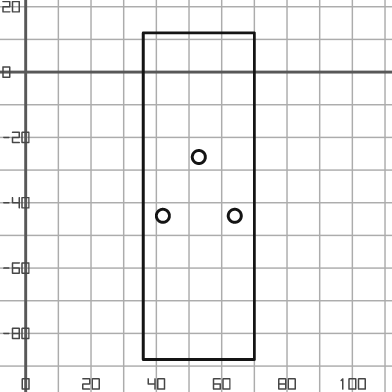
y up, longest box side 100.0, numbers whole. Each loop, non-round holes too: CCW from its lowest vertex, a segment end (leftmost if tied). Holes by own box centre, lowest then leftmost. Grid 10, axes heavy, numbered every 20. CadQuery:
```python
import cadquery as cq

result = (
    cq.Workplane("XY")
    .moveTo(36.0, -88.0)
    .lineTo(70.0, -88.0)
    .lineTo(70.0, 12.0)
    .lineTo(36.0, 12.0)
    .close()
    .moveTo(42.0, -44.0)
    .circle(2.0)
    .moveTo(64.0, -44.0)
    .circle(2.0)
    .moveTo(53.0, -26.0)
    .circle(2.0)
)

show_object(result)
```